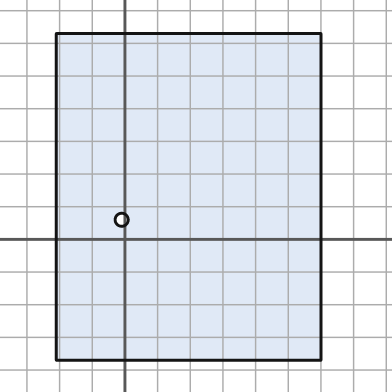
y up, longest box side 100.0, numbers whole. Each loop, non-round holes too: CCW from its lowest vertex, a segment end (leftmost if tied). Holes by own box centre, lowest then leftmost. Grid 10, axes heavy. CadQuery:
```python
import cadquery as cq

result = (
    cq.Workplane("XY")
    .moveTo(-21.0, -37.0)
    .lineTo(60.0, -37.0)
    .lineTo(60.0, 63.0)
    .lineTo(-21.0, 63.0)
    .close()
    .moveTo(-1.0, 6.0)
    .circle(2.0)
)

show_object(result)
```